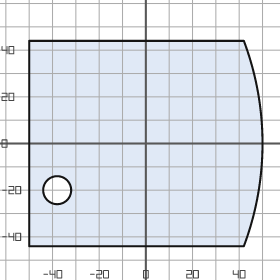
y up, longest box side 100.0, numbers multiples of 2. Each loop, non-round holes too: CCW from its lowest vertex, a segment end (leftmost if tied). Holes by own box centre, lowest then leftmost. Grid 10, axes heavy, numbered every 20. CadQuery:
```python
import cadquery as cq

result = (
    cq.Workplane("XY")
    .moveTo(-50.0, -44.0)
    .lineTo(42.0, -44.0)
    .threePointArc((50.0, 0.0), (42.0, 44.0))
    .lineTo(-50.0, 44.0)
    .close()
    .moveTo(-38.0, -20.0)
    .circle(6.0)
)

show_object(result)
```